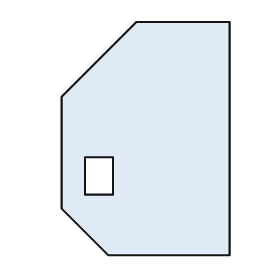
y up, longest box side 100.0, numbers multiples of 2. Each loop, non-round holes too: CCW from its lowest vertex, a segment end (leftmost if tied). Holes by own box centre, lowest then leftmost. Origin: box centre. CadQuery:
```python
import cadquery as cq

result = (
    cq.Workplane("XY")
    .moveTo(-16.0, -50.0)
    .lineTo(36.0, -50.0)
    .lineTo(36.0, 50.0)
    .lineTo(-4.0, 50.0)
    .lineTo(-36.0, 18.0)
    .lineTo(-36.0, -30.0)
    .close()
    .moveTo(-26.0, -24.0)
    .lineTo(-14.0, -24.0)
    .lineTo(-14.0, -8.0)
    .lineTo(-26.0, -8.0)
    .close()
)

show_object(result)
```